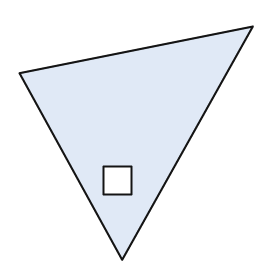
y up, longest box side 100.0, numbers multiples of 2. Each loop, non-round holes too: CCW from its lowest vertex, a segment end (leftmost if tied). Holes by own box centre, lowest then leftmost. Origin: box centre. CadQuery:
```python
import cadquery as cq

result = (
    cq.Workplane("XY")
    .moveTo(-6.0, -50.0)
    .lineTo(50.0, 50.0)
    .lineTo(-50.0, 30.0)
    .close()
    .moveTo(-14.0, -22.0)
    .lineTo(-2.0, -22.0)
    .lineTo(-2.0, -10.0)
    .lineTo(-14.0, -10.0)
    .close()
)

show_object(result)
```